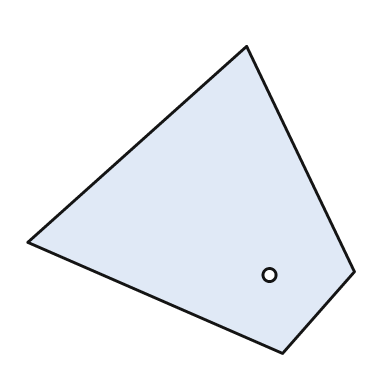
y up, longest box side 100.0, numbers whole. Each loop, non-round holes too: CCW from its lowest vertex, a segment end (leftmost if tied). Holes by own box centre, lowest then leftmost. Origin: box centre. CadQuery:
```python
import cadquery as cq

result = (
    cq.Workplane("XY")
    .moveTo(28.0, -47.0)
    .lineTo(50.0, -22.0)
    .lineTo(17.0, 47.0)
    .lineTo(-50.0, -13.0)
    .close()
    .moveTo(24.0, -23.0)
    .circle(2.0)
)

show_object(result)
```